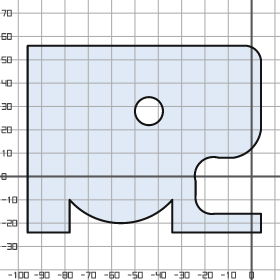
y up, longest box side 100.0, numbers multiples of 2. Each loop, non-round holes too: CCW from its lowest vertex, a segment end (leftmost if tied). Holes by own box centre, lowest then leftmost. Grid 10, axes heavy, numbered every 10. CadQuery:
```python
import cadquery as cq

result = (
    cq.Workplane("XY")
    .moveTo(-96.0, -24.0)
    .lineTo(-78.0, -24.0)
    .lineTo(-78.0, -10.0)
    .threePointArc((-56.0, -20.0), (-34.0, -10.0))
    .lineTo(-34.0, -24.0)
    .lineTo(4.0, -24.0)
    .lineTo(4.0, -16.0)
    .lineTo(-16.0, -16.0)
    .threePointArc((-22.0, -14.0), (-24.0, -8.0))
    .lineTo(-24.0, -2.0)
    .threePointArc((-22.0, 6.0), (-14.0, 8.0))
    .lineTo(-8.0, 8.0)
    .threePointArc((0.0, 12.0), (4.0, 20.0))
    .lineTo(4.0, 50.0)
    .threePointArc((2.0, 54.0), (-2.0, 56.0))
    .lineTo(-96.0, 56.0)
    .close()
    .moveTo(-44.0, 28.0)
    .circle(6.0)
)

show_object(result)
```